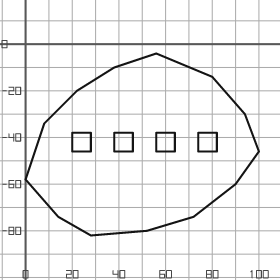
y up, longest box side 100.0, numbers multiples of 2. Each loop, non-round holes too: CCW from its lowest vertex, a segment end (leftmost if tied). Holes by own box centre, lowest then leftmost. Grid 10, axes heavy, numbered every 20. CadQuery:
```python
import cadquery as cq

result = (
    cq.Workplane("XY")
    .moveTo(28.0, -82.0)
    .lineTo(52.0, -80.0)
    .lineTo(72.0, -74.0)
    .lineTo(90.0, -60.0)
    .lineTo(100.0, -46.0)
    .lineTo(94.0, -30.0)
    .lineTo(80.0, -14.0)
    .lineTo(56.0, -4.0)
    .lineTo(38.0, -10.0)
    .lineTo(22.0, -20.0)
    .lineTo(8.0, -34.0)
    .lineTo(0.0, -58.0)
    .lineTo(14.0, -74.0)
    .close()
    .moveTo(20.0, -46.0)
    .lineTo(28.0, -46.0)
    .lineTo(28.0, -38.0)
    .lineTo(20.0, -38.0)
    .close()
    .moveTo(38.0, -46.0)
    .lineTo(46.0, -46.0)
    .lineTo(46.0, -38.0)
    .lineTo(38.0, -38.0)
    .close()
    .moveTo(56.0, -46.0)
    .lineTo(64.0, -46.0)
    .lineTo(64.0, -38.0)
    .lineTo(56.0, -38.0)
    .close()
    .moveTo(74.0, -46.0)
    .lineTo(82.0, -46.0)
    .lineTo(82.0, -38.0)
    .lineTo(74.0, -38.0)
    .close()
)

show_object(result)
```